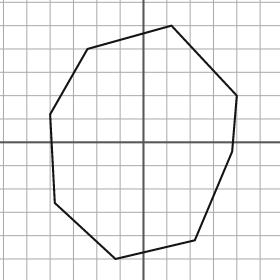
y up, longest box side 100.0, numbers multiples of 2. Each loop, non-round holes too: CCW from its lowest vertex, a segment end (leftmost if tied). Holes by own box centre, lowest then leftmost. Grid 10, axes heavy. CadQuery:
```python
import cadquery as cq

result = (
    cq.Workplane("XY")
    .moveTo(-12.0, -50.0)
    .lineTo(22.0, -42.0)
    .lineTo(38.0, -4.0)
    .lineTo(40.0, 20.0)
    .lineTo(12.0, 50.0)
    .lineTo(-24.0, 40.0)
    .lineTo(-40.0, 12.0)
    .lineTo(-38.0, -26.0)
    .close()
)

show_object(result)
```